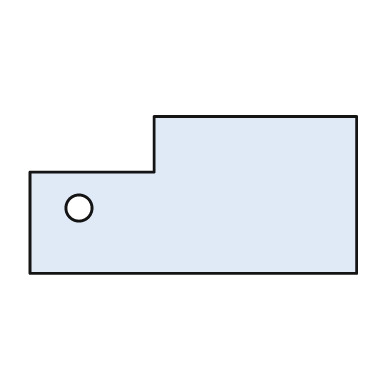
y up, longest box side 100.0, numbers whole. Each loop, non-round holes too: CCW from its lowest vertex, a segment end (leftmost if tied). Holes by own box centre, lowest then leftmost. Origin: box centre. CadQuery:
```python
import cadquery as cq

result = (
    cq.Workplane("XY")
    .moveTo(-50.0, -24.0)
    .lineTo(50.0, -24.0)
    .lineTo(50.0, 24.0)
    .lineTo(-12.0, 24.0)
    .lineTo(-12.0, 7.0)
    .lineTo(-50.0, 7.0)
    .close()
    .moveTo(-35.0, -4.0)
    .circle(4.0)
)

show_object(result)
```